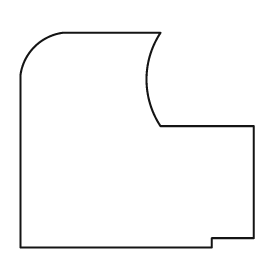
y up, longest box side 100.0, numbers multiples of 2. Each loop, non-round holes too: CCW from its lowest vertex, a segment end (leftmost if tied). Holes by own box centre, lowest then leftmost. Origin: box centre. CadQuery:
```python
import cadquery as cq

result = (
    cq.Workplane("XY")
    .moveTo(-50.0, -46.0)
    .lineTo(32.0, -46.0)
    .lineTo(32.0, -42.0)
    .lineTo(50.0, -42.0)
    .lineTo(50.0, 6.0)
    .lineTo(10.0, 6.0)
    .threePointArc((4.0, 26.0), (10.0, 46.0))
    .lineTo(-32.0, 46.0)
    .threePointArc((-44.0, 40.0), (-50.0, 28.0))
    .close()
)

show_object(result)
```